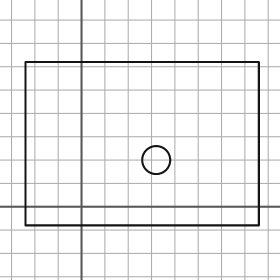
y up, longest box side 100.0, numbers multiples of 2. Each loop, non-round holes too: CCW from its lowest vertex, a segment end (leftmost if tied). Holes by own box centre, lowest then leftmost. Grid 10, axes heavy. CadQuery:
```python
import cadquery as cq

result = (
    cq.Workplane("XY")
    .moveTo(-24.0, -8.0)
    .lineTo(76.0, -8.0)
    .lineTo(76.0, 62.0)
    .lineTo(-24.0, 62.0)
    .close()
    .moveTo(32.0, 20.0)
    .circle(6.0)
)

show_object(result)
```